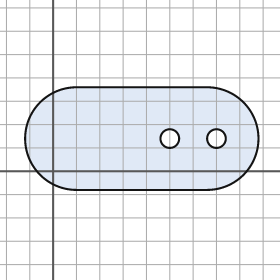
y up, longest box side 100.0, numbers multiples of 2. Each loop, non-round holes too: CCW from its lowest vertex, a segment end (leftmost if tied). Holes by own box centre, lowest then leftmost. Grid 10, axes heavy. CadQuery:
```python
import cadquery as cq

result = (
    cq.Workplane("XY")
    .moveTo(10.0, -8.0)
    .lineTo(66.0, -8.0)
    .threePointArc((88.0, 14.0), (66.0, 36.0))
    .lineTo(10.0, 36.0)
    .threePointArc((-12.0, 14.0), (10.0, -8.0))
    .close()
    .moveTo(50.0, 14.0)
    .circle(4.0)
    .moveTo(70.0, 14.0)
    .circle(4.0)
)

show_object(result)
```